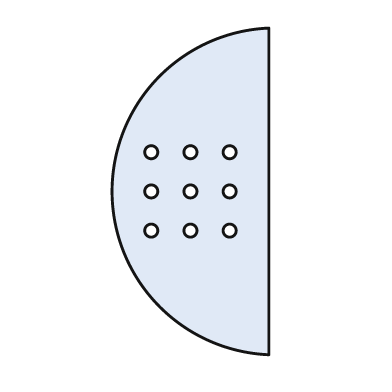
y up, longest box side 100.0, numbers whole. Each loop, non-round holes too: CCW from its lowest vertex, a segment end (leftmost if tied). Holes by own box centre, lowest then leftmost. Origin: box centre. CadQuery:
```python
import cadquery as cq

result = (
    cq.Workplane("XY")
    .moveTo(24.0, -50.0)
    .lineTo(24.0, 50.0)
    .threePointArc((-24.0, 0.0), (24.0, -50.0))
    .close()
    .moveTo(-12.0, -12.0)
    .circle(2.0)
    .moveTo(0.0, -12.0)
    .circle(2.0)
    .moveTo(12.0, -12.0)
    .circle(2.0)
    .moveTo(-12.0, 0.0)
    .circle(2.0)
    .moveTo(0.0, 0.0)
    .circle(2.0)
    .moveTo(12.0, 0.0)
    .circle(2.0)
    .moveTo(-12.0, 12.0)
    .circle(2.0)
    .moveTo(0.0, 12.0)
    .circle(2.0)
    .moveTo(12.0, 12.0)
    .circle(2.0)
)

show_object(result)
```